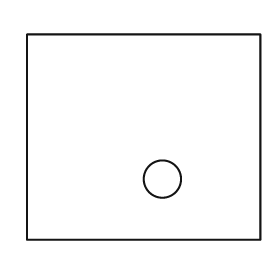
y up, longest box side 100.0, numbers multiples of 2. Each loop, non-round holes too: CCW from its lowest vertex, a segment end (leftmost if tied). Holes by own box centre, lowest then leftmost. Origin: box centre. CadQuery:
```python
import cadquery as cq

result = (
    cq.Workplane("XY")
    .moveTo(-50.0, -44.0)
    .lineTo(50.0, -44.0)
    .lineTo(50.0, 44.0)
    .lineTo(-50.0, 44.0)
    .close()
    .moveTo(8.0, -18.0)
    .circle(8.0)
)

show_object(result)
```